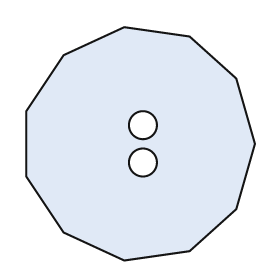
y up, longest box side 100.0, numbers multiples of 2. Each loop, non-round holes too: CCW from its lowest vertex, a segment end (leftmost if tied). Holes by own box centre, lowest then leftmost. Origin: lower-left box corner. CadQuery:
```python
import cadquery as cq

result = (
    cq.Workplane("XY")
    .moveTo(42.0, 0.0)
    .lineTo(70.0, 4.0)
    .lineTo(90.0, 22.0)
    .lineTo(98.0, 50.0)
    .lineTo(90.0, 78.0)
    .lineTo(70.0, 96.0)
    .lineTo(42.0, 100.0)
    .lineTo(16.0, 88.0)
    .lineTo(0.0, 64.0)
    .lineTo(0.0, 36.0)
    .lineTo(16.0, 12.0)
    .close()
    .moveTo(50.0, 42.0)
    .circle(6.0)
    .moveTo(50.0, 58.0)
    .circle(6.0)
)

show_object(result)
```